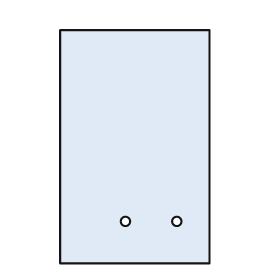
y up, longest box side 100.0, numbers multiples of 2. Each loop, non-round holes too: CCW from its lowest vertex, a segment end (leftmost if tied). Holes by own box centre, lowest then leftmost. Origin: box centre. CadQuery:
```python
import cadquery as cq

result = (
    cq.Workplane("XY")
    .moveTo(-32.0, -50.0)
    .lineTo(32.0, -50.0)
    .lineTo(32.0, 50.0)
    .lineTo(-32.0, 50.0)
    .close()
    .moveTo(-4.0, -32.0)
    .circle(2.0)
    .moveTo(18.0, -32.0)
    .circle(2.0)
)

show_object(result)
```